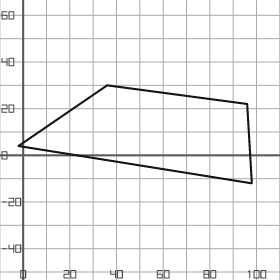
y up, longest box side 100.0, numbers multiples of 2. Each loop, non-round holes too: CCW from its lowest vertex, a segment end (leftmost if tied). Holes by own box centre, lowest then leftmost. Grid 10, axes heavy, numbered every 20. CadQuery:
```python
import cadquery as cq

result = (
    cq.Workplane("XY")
    .moveTo(98.0, -12.0)
    .lineTo(96.0, 22.0)
    .lineTo(36.0, 30.0)
    .lineTo(-2.0, 4.0)
    .close()
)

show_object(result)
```